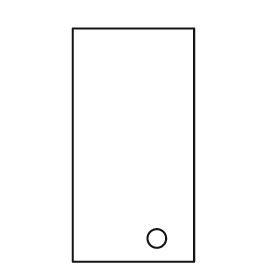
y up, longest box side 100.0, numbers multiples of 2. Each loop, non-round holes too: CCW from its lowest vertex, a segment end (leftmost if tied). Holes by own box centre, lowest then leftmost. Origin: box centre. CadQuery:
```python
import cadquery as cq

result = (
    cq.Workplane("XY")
    .moveTo(-26.0, -50.0)
    .lineTo(26.0, -50.0)
    .lineTo(26.0, 50.0)
    .lineTo(-26.0, 50.0)
    .close()
    .moveTo(10.0, -40.0)
    .circle(4.0)
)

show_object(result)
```